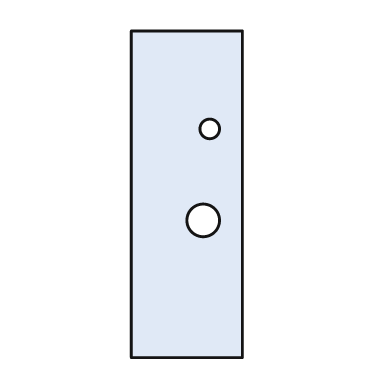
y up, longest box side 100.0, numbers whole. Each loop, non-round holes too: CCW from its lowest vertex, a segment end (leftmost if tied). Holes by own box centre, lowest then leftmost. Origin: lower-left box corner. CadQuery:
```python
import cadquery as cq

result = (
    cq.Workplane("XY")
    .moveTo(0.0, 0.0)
    .lineTo(34.0, 0.0)
    .lineTo(34.0, 100.0)
    .lineTo(0.0, 100.0)
    .close()
    .moveTo(22.0, 42.0)
    .circle(5.0)
    .moveTo(24.0, 70.0)
    .circle(3.0)
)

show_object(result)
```